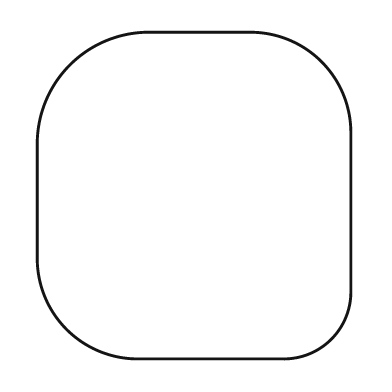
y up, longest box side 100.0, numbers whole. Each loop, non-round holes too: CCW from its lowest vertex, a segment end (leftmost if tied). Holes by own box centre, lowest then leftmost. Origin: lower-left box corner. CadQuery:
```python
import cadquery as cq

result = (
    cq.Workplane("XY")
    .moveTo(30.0, 0.0)
    .lineTo(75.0, 0.0)
    .threePointArc((90.0, 6.0), (96.0, 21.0))
    .lineTo(96.0, 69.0)
    .threePointArc((87.0, 91.0), (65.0, 100.0))
    .lineTo(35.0, 100.0)
    .threePointArc((10.0, 90.0), (0.0, 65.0))
    .lineTo(0.0, 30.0)
    .threePointArc((9.0, 9.0), (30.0, 0.0))
    .close()
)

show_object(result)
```